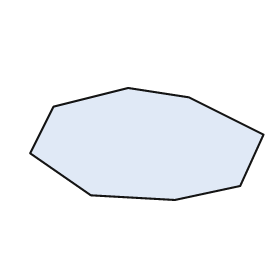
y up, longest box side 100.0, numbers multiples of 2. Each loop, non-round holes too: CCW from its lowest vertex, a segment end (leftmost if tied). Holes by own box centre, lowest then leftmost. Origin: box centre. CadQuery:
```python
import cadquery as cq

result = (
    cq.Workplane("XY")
    .moveTo(12.0, -24.0)
    .lineTo(40.0, -18.0)
    .lineTo(50.0, 4.0)
    .lineTo(18.0, 20.0)
    .lineTo(-8.0, 24.0)
    .lineTo(-40.0, 16.0)
    .lineTo(-50.0, -4.0)
    .lineTo(-24.0, -22.0)
    .close()
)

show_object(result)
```